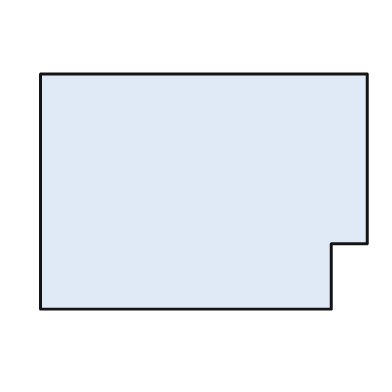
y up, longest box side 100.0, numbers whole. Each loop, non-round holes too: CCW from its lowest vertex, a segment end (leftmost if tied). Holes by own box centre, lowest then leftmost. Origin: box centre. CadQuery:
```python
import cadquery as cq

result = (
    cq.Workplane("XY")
    .moveTo(-50.0, -36.0)
    .lineTo(39.0, -36.0)
    .lineTo(39.0, -16.0)
    .lineTo(50.0, -16.0)
    .lineTo(50.0, 36.0)
    .lineTo(-50.0, 36.0)
    .close()
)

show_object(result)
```